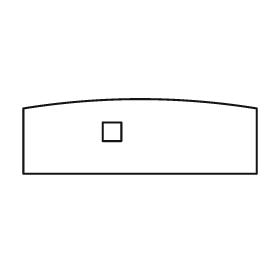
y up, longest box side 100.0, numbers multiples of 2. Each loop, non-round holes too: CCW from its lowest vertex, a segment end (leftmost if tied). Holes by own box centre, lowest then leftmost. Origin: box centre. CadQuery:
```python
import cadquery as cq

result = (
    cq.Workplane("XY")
    .moveTo(-50.0, -16.0)
    .lineTo(50.0, -16.0)
    .lineTo(50.0, 12.0)
    .threePointArc((0.0, 16.0), (-50.0, 12.0))
    .close()
    .moveTo(-16.0, -2.0)
    .lineTo(-8.0, -2.0)
    .lineTo(-8.0, 6.0)
    .lineTo(-16.0, 6.0)
    .close()
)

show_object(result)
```